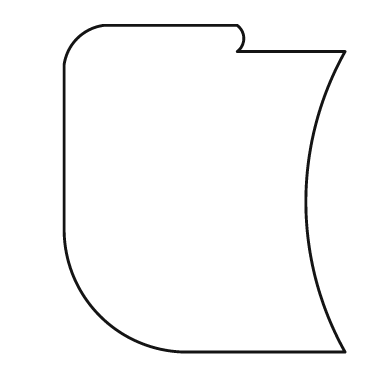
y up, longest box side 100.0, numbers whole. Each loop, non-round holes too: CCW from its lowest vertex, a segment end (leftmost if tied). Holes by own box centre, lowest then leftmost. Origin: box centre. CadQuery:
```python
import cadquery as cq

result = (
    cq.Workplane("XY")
    .moveTo(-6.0, -50.0)
    .lineTo(43.0, -50.0)
    .threePointArc((31.0, -4.0), (43.0, 42.0))
    .lineTo(10.0, 42.0)
    .threePointArc((12.0, 46.0), (10.0, 50.0))
    .lineTo(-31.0, 50.0)
    .threePointArc((-39.0, 46.0), (-43.0, 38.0))
    .lineTo(-43.0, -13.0)
    .threePointArc((-32.0, -39.0), (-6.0, -50.0))
    .close()
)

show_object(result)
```